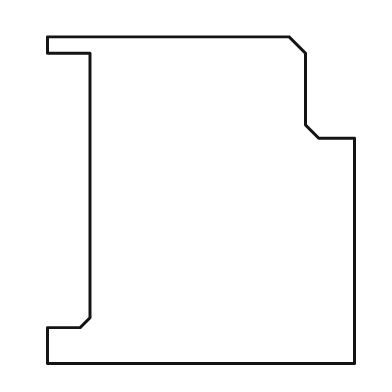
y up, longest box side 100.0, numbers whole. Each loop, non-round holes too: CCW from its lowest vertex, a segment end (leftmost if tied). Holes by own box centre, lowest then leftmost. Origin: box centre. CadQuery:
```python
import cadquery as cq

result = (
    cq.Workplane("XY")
    .moveTo(-47.0, -50.0)
    .lineTo(47.0, -50.0)
    .lineTo(47.0, 19.0)
    .lineTo(36.0, 19.0)
    .lineTo(32.0, 23.0)
    .lineTo(32.0, 45.0)
    .lineTo(27.0, 50.0)
    .lineTo(-47.0, 50.0)
    .lineTo(-47.0, 45.0)
    .lineTo(-34.0, 45.0)
    .lineTo(-34.0, -36.0)
    .lineTo(-37.0, -39.0)
    .lineTo(-47.0, -39.0)
    .close()
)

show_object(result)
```